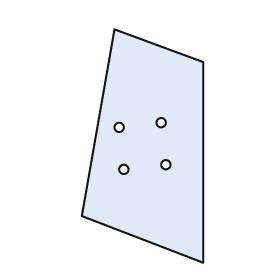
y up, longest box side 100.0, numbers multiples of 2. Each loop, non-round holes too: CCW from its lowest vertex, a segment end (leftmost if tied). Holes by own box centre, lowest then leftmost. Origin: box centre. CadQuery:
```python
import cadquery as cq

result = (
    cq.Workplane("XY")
    .moveTo(26.0, -50.0)
    .lineTo(26.0, 36.0)
    .lineTo(-12.0, 50.0)
    .lineTo(-26.0, -30.0)
    .close()
    .moveTo(-8.0, -10.0)
    .circle(2.0)
    .moveTo(10.0, -8.0)
    .circle(2.0)
    .moveTo(-10.0, 8.0)
    .circle(2.0)
    .moveTo(8.0, 10.0)
    .circle(2.0)
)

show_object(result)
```